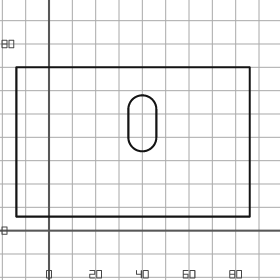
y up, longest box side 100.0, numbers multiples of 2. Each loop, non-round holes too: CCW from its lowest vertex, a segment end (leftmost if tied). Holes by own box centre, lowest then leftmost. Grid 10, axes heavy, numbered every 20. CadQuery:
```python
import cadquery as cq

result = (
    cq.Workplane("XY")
    .moveTo(-14.0, 6.0)
    .lineTo(86.0, 6.0)
    .lineTo(86.0, 70.0)
    .lineTo(-14.0, 70.0)
    .close()
    .moveTo(34.0, 40.0)
    .threePointArc((40.0, 34.0), (46.0, 40.0))
    .lineTo(46.0, 52.0)
    .threePointArc((40.0, 58.0), (34.0, 52.0))
    .close()
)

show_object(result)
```